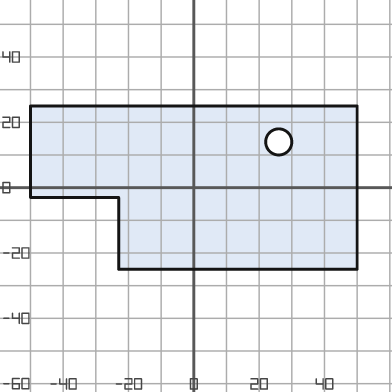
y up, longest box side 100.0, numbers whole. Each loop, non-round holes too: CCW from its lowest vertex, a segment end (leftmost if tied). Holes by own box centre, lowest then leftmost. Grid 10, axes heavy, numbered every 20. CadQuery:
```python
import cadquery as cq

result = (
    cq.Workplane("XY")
    .moveTo(-23.0, -25.0)
    .lineTo(50.0, -25.0)
    .lineTo(50.0, 25.0)
    .lineTo(-50.0, 25.0)
    .lineTo(-50.0, -3.0)
    .lineTo(-23.0, -3.0)
    .close()
    .moveTo(26.0, 14.0)
    .circle(4.0)
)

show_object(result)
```